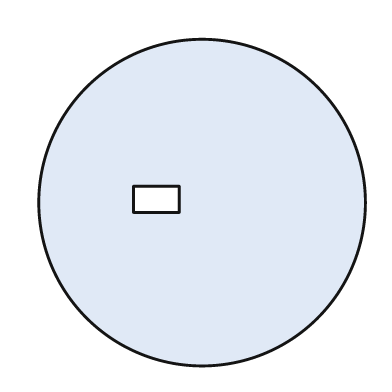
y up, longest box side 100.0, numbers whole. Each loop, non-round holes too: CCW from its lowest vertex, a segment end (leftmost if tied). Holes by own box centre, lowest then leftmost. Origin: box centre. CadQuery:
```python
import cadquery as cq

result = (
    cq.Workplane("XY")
    .moveTo(0.0, 0.0)
    .circle(50.0)
    .moveTo(-21.0, -3.0)
    .lineTo(-7.0, -3.0)
    .lineTo(-7.0, 5.0)
    .lineTo(-21.0, 5.0)
    .close()
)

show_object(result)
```